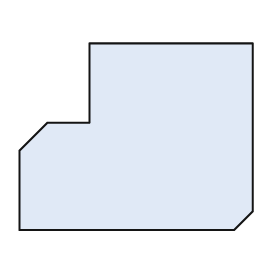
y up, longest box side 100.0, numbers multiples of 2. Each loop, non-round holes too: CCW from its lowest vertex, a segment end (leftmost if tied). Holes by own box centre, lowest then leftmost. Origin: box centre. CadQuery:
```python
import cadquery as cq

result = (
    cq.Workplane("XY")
    .moveTo(-50.0, -40.0)
    .lineTo(42.0, -40.0)
    .lineTo(50.0, -32.0)
    .lineTo(50.0, 40.0)
    .lineTo(-20.0, 40.0)
    .lineTo(-20.0, 6.0)
    .lineTo(-38.0, 6.0)
    .lineTo(-50.0, -6.0)
    .close()
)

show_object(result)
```